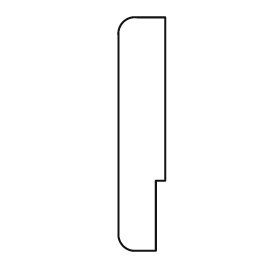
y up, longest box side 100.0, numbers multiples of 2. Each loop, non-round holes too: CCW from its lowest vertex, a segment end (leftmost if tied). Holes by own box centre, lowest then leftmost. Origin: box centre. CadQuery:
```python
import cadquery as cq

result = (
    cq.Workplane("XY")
    .moveTo(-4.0, -50.0)
    .lineTo(6.0, -50.0)
    .lineTo(6.0, -20.0)
    .lineTo(10.0, -20.0)
    .lineTo(10.0, 50.0)
    .lineTo(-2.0, 50.0)
    .threePointArc((-8.0, 48.0), (-10.0, 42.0))
    .lineTo(-10.0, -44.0)
    .threePointArc((-8.0, -48.0), (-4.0, -50.0))
    .close()
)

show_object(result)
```